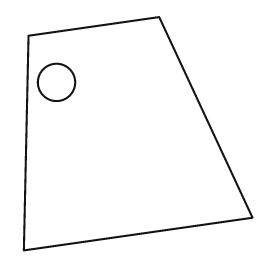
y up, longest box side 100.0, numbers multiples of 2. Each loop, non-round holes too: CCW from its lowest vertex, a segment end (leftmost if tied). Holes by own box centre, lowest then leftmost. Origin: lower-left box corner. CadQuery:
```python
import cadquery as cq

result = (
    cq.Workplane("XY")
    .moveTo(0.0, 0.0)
    .lineTo(98.0, 14.0)
    .lineTo(58.0, 100.0)
    .lineTo(2.0, 92.0)
    .close()
    .moveTo(14.0, 72.0)
    .circle(8.0)
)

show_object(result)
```